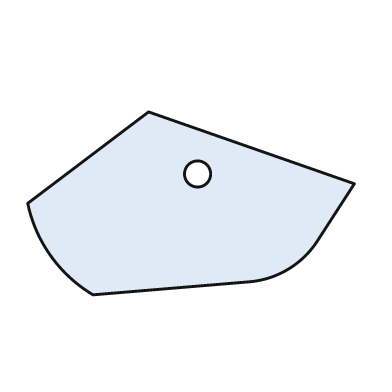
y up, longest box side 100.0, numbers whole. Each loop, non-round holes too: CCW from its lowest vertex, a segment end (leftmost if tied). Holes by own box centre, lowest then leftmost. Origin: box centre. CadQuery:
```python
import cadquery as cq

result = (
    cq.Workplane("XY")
    .moveTo(-30.0, -28.0)
    .lineTo(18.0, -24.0)
    .threePointArc((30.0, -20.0), (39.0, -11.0))
    .lineTo(50.0, 6.0)
    .lineTo(-13.0, 28.0)
    .lineTo(-50.0, 0.0)
    .threePointArc((-43.0, -16.0), (-30.0, -28.0))
    .close()
    .moveTo(2.0, 9.0)
    .circle(4.0)
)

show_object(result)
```